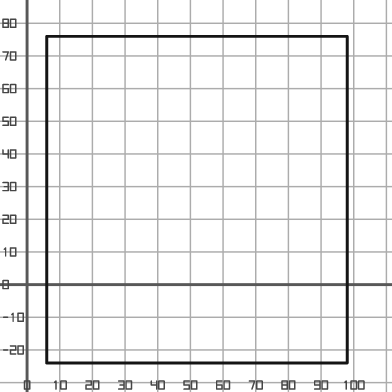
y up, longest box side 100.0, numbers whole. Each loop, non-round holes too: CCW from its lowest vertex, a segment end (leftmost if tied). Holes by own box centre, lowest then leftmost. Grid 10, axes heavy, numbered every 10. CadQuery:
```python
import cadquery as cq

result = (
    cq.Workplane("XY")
    .moveTo(6.0, -24.0)
    .lineTo(98.0, -24.0)
    .lineTo(98.0, 76.0)
    .lineTo(6.0, 76.0)
    .close()
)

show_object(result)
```